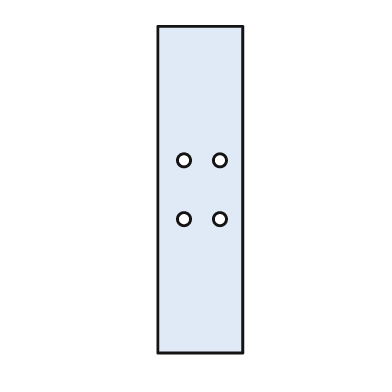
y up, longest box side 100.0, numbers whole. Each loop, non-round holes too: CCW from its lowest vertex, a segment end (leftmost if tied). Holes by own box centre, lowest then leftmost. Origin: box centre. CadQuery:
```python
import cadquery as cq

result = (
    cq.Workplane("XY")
    .moveTo(-13.0, -50.0)
    .lineTo(13.0, -50.0)
    .lineTo(13.0, 50.0)
    .lineTo(-13.0, 50.0)
    .close()
    .moveTo(-5.0, -9.0)
    .circle(2.0)
    .moveTo(6.0, -9.0)
    .circle(2.0)
    .moveTo(-5.0, 9.0)
    .circle(2.0)
    .moveTo(6.0, 9.0)
    .circle(2.0)
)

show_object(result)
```